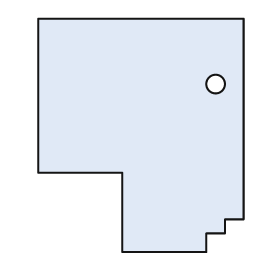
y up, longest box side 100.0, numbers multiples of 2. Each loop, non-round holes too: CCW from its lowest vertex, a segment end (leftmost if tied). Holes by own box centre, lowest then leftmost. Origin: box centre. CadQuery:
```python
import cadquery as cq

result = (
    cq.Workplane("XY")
    .moveTo(-8.0, -50.0)
    .lineTo(28.0, -50.0)
    .lineTo(28.0, -42.0)
    .lineTo(36.0, -42.0)
    .lineTo(36.0, -36.0)
    .lineTo(44.0, -36.0)
    .lineTo(44.0, 50.0)
    .lineTo(-44.0, 50.0)
    .lineTo(-44.0, -16.0)
    .lineTo(-8.0, -16.0)
    .close()
    .moveTo(32.0, 22.0)
    .circle(4.0)
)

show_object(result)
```